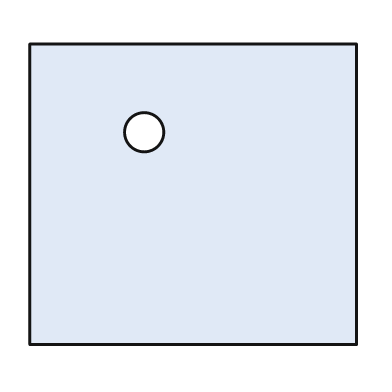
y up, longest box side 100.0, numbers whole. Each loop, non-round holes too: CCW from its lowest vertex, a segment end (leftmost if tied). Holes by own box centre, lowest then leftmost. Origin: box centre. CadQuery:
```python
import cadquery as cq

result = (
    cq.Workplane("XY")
    .moveTo(-50.0, -46.0)
    .lineTo(50.0, -46.0)
    .lineTo(50.0, 46.0)
    .lineTo(-50.0, 46.0)
    .close()
    .moveTo(-15.0, 19.0)
    .circle(6.0)
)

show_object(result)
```